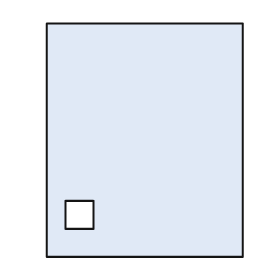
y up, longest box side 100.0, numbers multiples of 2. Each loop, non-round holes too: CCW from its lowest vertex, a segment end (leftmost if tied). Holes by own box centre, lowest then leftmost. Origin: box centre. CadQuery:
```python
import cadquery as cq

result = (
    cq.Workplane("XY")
    .moveTo(-42.0, -50.0)
    .lineTo(42.0, -50.0)
    .lineTo(42.0, 50.0)
    .lineTo(-42.0, 50.0)
    .close()
    .moveTo(-34.0, -38.0)
    .lineTo(-22.0, -38.0)
    .lineTo(-22.0, -26.0)
    .lineTo(-34.0, -26.0)
    .close()
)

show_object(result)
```